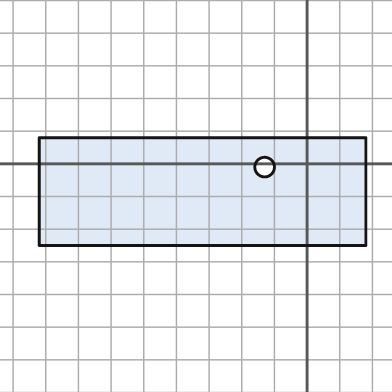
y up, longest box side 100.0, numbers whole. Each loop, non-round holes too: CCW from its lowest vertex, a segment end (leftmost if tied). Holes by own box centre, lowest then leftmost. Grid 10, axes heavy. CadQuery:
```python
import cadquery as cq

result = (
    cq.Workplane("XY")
    .moveTo(-82.0, -25.0)
    .lineTo(18.0, -25.0)
    .lineTo(18.0, 8.0)
    .lineTo(-82.0, 8.0)
    .close()
    .moveTo(-13.0, -1.0)
    .circle(3.0)
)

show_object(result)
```